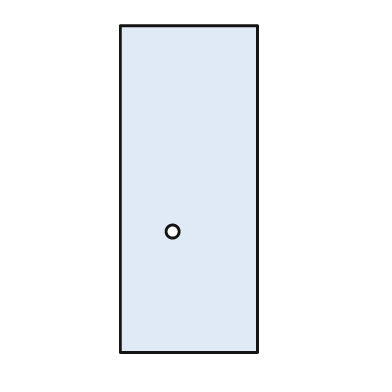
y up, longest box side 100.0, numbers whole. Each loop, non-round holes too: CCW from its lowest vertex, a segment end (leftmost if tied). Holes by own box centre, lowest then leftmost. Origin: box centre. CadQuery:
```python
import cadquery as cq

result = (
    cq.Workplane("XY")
    .moveTo(-21.0, -50.0)
    .lineTo(21.0, -50.0)
    .lineTo(21.0, 50.0)
    .lineTo(-21.0, 50.0)
    .close()
    .moveTo(-5.0, -13.0)
    .circle(2.0)
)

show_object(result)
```